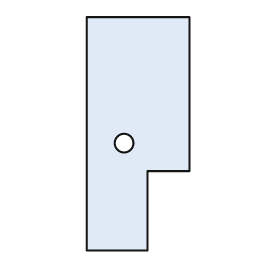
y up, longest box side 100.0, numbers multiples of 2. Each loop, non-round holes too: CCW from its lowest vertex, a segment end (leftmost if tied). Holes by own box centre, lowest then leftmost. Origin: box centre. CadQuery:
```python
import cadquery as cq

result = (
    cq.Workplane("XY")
    .moveTo(-22.0, -50.0)
    .lineTo(4.0, -50.0)
    .lineTo(4.0, -16.0)
    .lineTo(22.0, -16.0)
    .lineTo(22.0, 50.0)
    .lineTo(-22.0, 50.0)
    .close()
    .moveTo(-6.0, -4.0)
    .circle(4.0)
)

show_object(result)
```